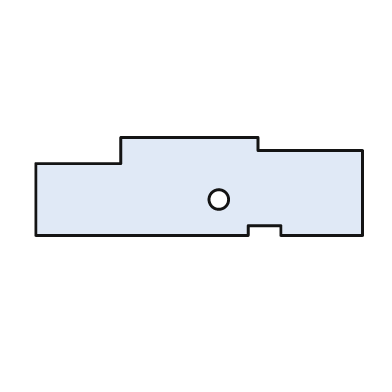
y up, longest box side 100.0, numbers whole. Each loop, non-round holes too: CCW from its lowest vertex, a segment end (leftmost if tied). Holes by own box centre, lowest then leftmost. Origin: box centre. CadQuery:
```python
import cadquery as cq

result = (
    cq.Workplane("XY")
    .moveTo(-50.0, -15.0)
    .lineTo(15.0, -15.0)
    .lineTo(15.0, -12.0)
    .lineTo(25.0, -12.0)
    .lineTo(25.0, -15.0)
    .lineTo(50.0, -15.0)
    .lineTo(50.0, 11.0)
    .lineTo(18.0, 11.0)
    .lineTo(18.0, 15.0)
    .lineTo(-24.0, 15.0)
    .lineTo(-24.0, 7.0)
    .lineTo(-50.0, 7.0)
    .close()
    .moveTo(6.0, -4.0)
    .circle(3.0)
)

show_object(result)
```